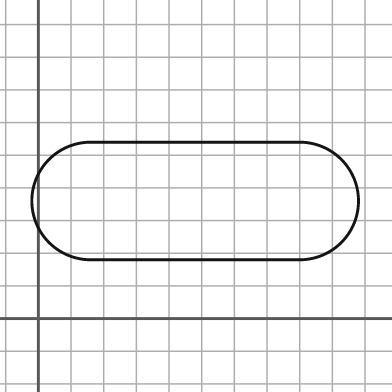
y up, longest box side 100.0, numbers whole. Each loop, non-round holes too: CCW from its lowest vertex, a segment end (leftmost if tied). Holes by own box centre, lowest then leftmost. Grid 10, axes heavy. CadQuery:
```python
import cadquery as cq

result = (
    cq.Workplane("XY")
    .moveTo(16.0, 18.0)
    .lineTo(80.0, 18.0)
    .threePointArc((98.0, 36.0), (80.0, 54.0))
    .lineTo(16.0, 54.0)
    .threePointArc((-2.0, 36.0), (16.0, 18.0))
    .close()
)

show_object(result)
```